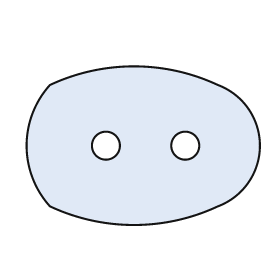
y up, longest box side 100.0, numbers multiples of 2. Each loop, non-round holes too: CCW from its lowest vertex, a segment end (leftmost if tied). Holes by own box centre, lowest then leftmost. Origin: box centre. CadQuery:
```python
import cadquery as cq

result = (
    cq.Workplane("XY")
    .moveTo(-40.0, -26.0)
    .threePointArc((-4.0, -34.0), (32.0, -26.0))
    .threePointArc((50.0, 0.0), (32.0, 26.0))
    .threePointArc((-4.0, 34.0), (-40.0, 26.0))
    .threePointArc((-50.0, 0.0), (-40.0, -26.0))
    .close()
    .moveTo(-16.0, 0.0)
    .circle(6.0)
    .moveTo(18.0, 0.0)
    .circle(6.0)
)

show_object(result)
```